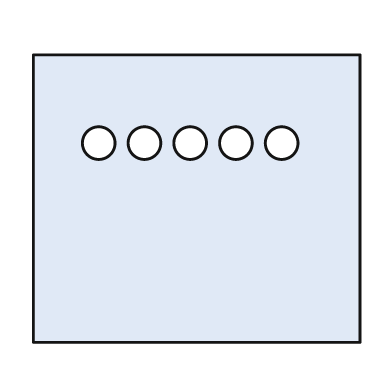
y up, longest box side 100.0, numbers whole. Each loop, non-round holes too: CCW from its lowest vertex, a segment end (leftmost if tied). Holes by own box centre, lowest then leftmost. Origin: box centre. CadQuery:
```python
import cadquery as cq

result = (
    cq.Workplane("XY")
    .moveTo(-50.0, -44.0)
    .lineTo(50.0, -44.0)
    .lineTo(50.0, 44.0)
    .lineTo(-50.0, 44.0)
    .close()
    .moveTo(-30.0, 17.0)
    .circle(5.0)
    .moveTo(-16.0, 17.0)
    .circle(5.0)
    .moveTo(-2.0, 17.0)
    .circle(5.0)
    .moveTo(12.0, 17.0)
    .circle(5.0)
    .moveTo(26.0, 17.0)
    .circle(5.0)
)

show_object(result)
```